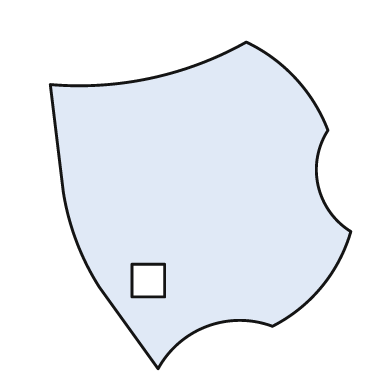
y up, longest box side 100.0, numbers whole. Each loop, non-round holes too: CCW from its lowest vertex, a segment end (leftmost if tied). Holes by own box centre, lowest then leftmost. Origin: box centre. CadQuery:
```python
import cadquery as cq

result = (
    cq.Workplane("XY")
    .moveTo(-13.0, -50.0)
    .threePointArc((2.0, -37.0), (22.0, -37.0))
    .threePointArc((37.0, -25.0), (46.0, -8.0))
    .threePointArc((36.0, 6.0), (39.0, 23.0))
    .threePointArc((29.0, 39.0), (14.0, 50.0))
    .threePointArc((-15.0, 39.0), (-46.0, 37.0))
    .lineTo(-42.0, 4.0)
    .threePointArc((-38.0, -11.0), (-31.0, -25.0))
    .close()
    .moveTo(-21.0, -28.0)
    .lineTo(-11.0, -28.0)
    .lineTo(-11.0, -18.0)
    .lineTo(-21.0, -18.0)
    .close()
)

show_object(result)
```